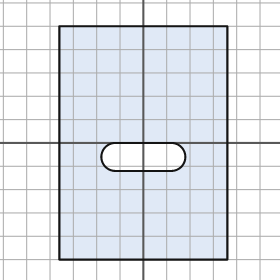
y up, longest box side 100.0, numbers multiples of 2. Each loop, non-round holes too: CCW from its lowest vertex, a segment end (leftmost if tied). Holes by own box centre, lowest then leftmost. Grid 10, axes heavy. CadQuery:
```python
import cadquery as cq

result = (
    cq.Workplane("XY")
    .moveTo(-36.0, -50.0)
    .lineTo(36.0, -50.0)
    .lineTo(36.0, 50.0)
    .lineTo(-36.0, 50.0)
    .close()
    .moveTo(-12.0, -12.0)
    .lineTo(12.0, -12.0)
    .threePointArc((18.0, -6.0), (12.0, 0.0))
    .lineTo(-12.0, 0.0)
    .threePointArc((-18.0, -6.0), (-12.0, -12.0))
    .close()
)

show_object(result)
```